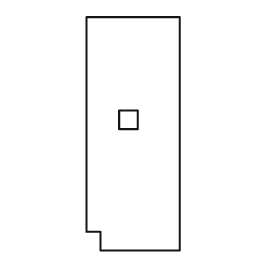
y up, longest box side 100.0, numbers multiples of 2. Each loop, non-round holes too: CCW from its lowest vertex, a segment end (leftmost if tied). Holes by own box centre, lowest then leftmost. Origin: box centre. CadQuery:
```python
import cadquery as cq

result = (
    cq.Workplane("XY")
    .moveTo(-14.0, -50.0)
    .lineTo(20.0, -50.0)
    .lineTo(20.0, 50.0)
    .lineTo(-20.0, 50.0)
    .lineTo(-20.0, -42.0)
    .lineTo(-14.0, -42.0)
    .close()
    .moveTo(-6.0, 2.0)
    .lineTo(2.0, 2.0)
    .lineTo(2.0, 10.0)
    .lineTo(-6.0, 10.0)
    .close()
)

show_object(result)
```